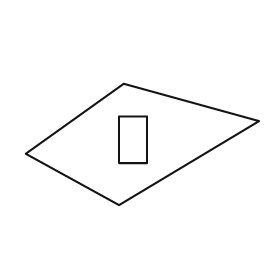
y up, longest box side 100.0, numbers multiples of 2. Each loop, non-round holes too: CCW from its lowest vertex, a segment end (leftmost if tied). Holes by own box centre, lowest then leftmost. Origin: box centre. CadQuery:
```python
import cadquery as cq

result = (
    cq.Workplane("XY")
    .moveTo(-10.0, -26.0)
    .lineTo(50.0, 10.0)
    .lineTo(-8.0, 26.0)
    .lineTo(-50.0, -4.0)
    .close()
    .moveTo(-10.0, -8.0)
    .lineTo(2.0, -8.0)
    .lineTo(2.0, 12.0)
    .lineTo(-10.0, 12.0)
    .close()
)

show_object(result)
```